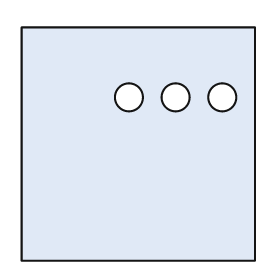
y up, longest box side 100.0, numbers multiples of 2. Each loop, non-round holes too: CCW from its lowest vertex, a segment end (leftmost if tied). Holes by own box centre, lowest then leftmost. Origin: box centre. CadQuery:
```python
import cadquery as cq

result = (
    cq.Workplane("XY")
    .moveTo(-50.0, -50.0)
    .lineTo(50.0, -50.0)
    .lineTo(50.0, 50.0)
    .lineTo(-50.0, 50.0)
    .close()
    .moveTo(-4.0, 20.0)
    .circle(6.0)
    .moveTo(16.0, 20.0)
    .circle(6.0)
    .moveTo(36.0, 20.0)
    .circle(6.0)
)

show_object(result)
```